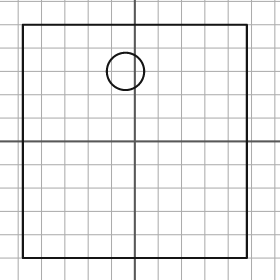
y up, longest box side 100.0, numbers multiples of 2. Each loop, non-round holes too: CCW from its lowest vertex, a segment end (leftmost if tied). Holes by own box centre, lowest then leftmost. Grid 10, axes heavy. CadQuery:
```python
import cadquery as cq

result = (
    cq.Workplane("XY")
    .moveTo(-48.0, -50.0)
    .lineTo(48.0, -50.0)
    .lineTo(48.0, 50.0)
    .lineTo(-48.0, 50.0)
    .close()
    .moveTo(-4.0, 30.0)
    .circle(8.0)
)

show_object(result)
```